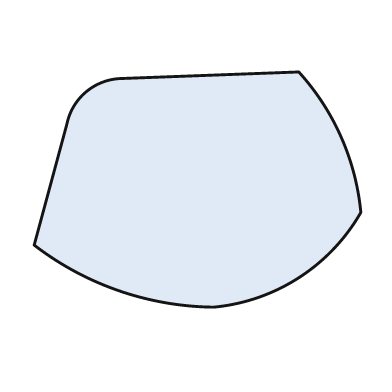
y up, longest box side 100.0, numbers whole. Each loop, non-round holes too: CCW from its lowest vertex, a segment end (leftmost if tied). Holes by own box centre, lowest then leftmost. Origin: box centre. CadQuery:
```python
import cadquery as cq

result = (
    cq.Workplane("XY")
    .moveTo(5.0, -36.0)
    .threePointArc((31.0, -27.0), (50.0, -7.0))
    .threePointArc((44.0, 16.0), (31.0, 36.0))
    .lineTo(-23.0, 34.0)
    .threePointArc((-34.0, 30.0), (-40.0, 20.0))
    .lineTo(-50.0, -17.0)
    .threePointArc((-24.0, -31.0), (5.0, -36.0))
    .close()
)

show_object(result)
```